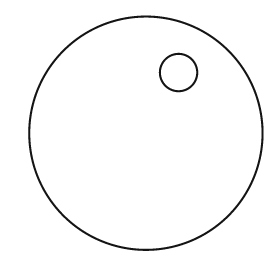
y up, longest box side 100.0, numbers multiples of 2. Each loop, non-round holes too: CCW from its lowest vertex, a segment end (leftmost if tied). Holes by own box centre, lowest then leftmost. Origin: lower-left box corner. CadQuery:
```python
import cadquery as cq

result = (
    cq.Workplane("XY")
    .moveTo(50.0, 50.0)
    .circle(50.0)
    .moveTo(64.0, 76.0)
    .circle(8.0)
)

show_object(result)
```